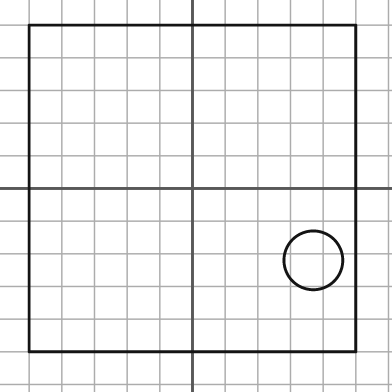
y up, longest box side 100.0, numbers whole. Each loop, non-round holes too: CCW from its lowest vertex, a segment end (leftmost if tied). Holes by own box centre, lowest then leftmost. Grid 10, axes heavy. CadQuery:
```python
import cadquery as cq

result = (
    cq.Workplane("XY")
    .moveTo(-50.0, -50.0)
    .lineTo(50.0, -50.0)
    .lineTo(50.0, 50.0)
    .lineTo(-50.0, 50.0)
    .close()
    .moveTo(37.0, -22.0)
    .circle(9.0)
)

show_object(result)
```